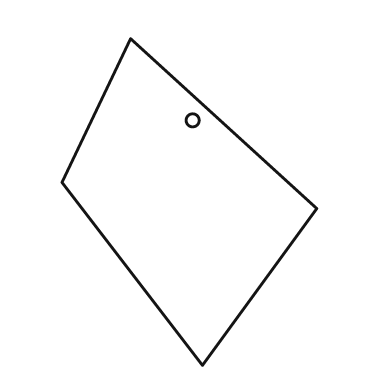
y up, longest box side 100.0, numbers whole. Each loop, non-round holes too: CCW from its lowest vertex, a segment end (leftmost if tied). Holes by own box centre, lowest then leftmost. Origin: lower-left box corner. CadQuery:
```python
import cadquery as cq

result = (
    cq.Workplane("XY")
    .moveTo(43.0, 0.0)
    .lineTo(78.0, 48.0)
    .lineTo(21.0, 100.0)
    .lineTo(0.0, 56.0)
    .close()
    .moveTo(40.0, 75.0)
    .circle(2.0)
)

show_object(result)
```